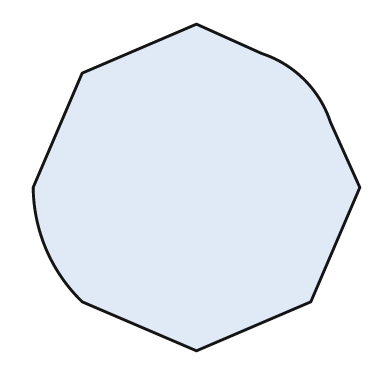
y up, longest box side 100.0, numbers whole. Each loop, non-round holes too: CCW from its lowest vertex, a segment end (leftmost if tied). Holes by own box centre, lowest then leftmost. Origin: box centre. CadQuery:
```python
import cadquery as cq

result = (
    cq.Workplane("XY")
    .moveTo(0.0, -50.0)
    .lineTo(35.0, -35.0)
    .lineTo(50.0, 0.0)
    .lineTo(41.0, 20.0)
    .threePointArc((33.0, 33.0), (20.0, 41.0))
    .lineTo(0.0, 50.0)
    .lineTo(-35.0, 35.0)
    .lineTo(-50.0, 0.0)
    .threePointArc((-46.0, -19.0), (-35.0, -35.0))
    .close()
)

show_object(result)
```